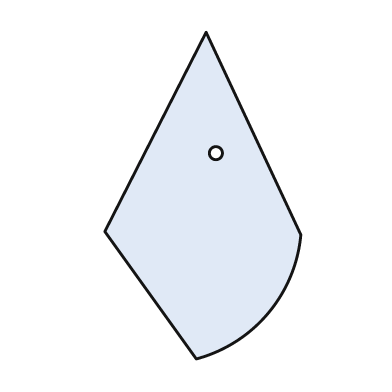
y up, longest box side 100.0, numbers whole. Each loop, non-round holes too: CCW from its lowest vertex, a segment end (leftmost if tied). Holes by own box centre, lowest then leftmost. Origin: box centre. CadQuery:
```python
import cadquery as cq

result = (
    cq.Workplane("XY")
    .moveTo(-2.0, -50.0)
    .threePointArc((20.0, -36.0), (30.0, -12.0))
    .lineTo(1.0, 50.0)
    .lineTo(-30.0, -11.0)
    .close()
    .moveTo(4.0, 13.0)
    .circle(2.0)
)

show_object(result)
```